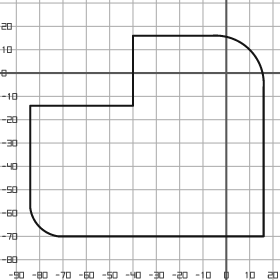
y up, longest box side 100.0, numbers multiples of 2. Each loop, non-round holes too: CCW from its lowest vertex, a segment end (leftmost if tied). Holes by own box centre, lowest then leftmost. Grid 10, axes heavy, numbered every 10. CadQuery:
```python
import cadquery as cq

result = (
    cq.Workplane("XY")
    .moveTo(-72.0, -70.0)
    .lineTo(16.0, -70.0)
    .lineTo(16.0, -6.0)
    .threePointArc((10.0, 10.0), (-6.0, 16.0))
    .lineTo(-40.0, 16.0)
    .lineTo(-40.0, -14.0)
    .lineTo(-84.0, -14.0)
    .lineTo(-84.0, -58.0)
    .threePointArc((-80.0, -66.0), (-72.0, -70.0))
    .close()
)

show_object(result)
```